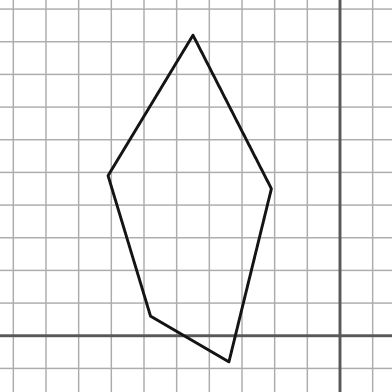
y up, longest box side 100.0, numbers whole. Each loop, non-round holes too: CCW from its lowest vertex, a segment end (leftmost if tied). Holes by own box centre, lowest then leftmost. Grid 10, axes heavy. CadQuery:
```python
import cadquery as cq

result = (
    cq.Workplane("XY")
    .moveTo(-34.0, -8.0)
    .lineTo(-21.0, 45.0)
    .lineTo(-45.0, 92.0)
    .lineTo(-71.0, 49.0)
    .lineTo(-58.0, 6.0)
    .close()
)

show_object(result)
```